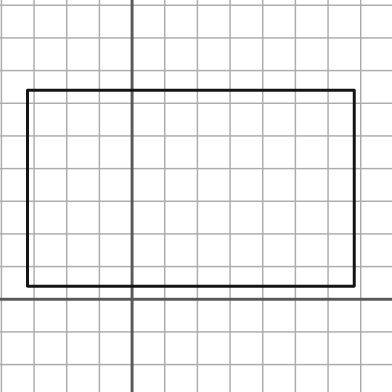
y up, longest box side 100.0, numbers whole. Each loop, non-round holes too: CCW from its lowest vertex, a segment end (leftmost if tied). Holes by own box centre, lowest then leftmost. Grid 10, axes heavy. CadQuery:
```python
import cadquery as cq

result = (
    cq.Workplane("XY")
    .moveTo(-32.0, 4.0)
    .lineTo(68.0, 4.0)
    .lineTo(68.0, 64.0)
    .lineTo(-32.0, 64.0)
    .close()
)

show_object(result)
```